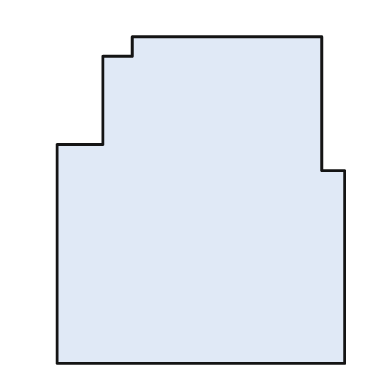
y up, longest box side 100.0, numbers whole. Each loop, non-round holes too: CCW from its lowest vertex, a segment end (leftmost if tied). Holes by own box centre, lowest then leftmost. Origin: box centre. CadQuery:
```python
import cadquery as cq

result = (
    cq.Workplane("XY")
    .moveTo(-44.0, -50.0)
    .lineTo(44.0, -50.0)
    .lineTo(44.0, 9.0)
    .lineTo(37.0, 9.0)
    .lineTo(37.0, 50.0)
    .lineTo(-21.0, 50.0)
    .lineTo(-21.0, 44.0)
    .lineTo(-30.0, 44.0)
    .lineTo(-30.0, 17.0)
    .lineTo(-44.0, 17.0)
    .close()
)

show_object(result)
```